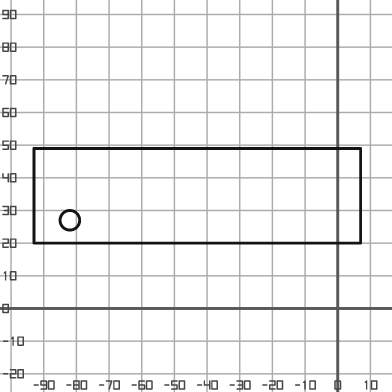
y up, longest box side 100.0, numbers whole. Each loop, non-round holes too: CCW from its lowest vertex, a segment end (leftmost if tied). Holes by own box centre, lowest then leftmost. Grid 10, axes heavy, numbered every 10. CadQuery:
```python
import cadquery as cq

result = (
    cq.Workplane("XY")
    .moveTo(-93.0, 20.0)
    .lineTo(7.0, 20.0)
    .lineTo(7.0, 49.0)
    .lineTo(-93.0, 49.0)
    .close()
    .moveTo(-82.0, 27.0)
    .circle(3.0)
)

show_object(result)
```